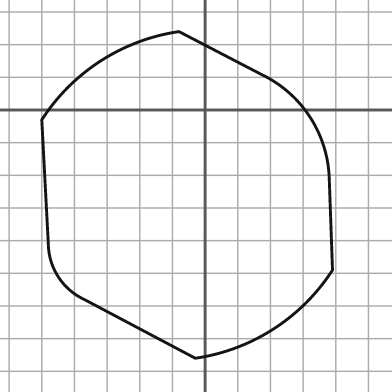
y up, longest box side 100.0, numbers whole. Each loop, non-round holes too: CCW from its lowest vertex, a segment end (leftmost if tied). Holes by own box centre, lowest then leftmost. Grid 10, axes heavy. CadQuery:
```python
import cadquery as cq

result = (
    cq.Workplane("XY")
    .moveTo(-3.0, -76.0)
    .threePointArc((21.0, -67.0), (39.0, -49.0))
    .lineTo(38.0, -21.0)
    .threePointArc((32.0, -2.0), (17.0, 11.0))
    .lineTo(-8.0, 24.0)
    .threePointArc((-32.0, 15.0), (-50.0, -3.0))
    .lineTo(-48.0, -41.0)
    .threePointArc((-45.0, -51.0), (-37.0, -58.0))
    .close()
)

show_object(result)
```